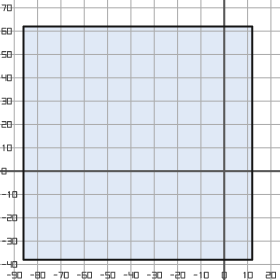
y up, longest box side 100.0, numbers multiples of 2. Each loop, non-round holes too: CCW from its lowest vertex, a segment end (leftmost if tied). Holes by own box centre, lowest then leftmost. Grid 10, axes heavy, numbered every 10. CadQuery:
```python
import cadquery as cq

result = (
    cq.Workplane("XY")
    .moveTo(-86.0, -38.0)
    .lineTo(12.0, -38.0)
    .lineTo(12.0, 62.0)
    .lineTo(-86.0, 62.0)
    .close()
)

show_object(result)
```